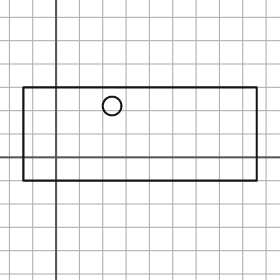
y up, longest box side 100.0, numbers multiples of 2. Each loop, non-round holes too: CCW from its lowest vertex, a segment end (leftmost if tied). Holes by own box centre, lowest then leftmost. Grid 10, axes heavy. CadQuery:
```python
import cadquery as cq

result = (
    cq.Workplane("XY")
    .moveTo(-14.0, -10.0)
    .lineTo(86.0, -10.0)
    .lineTo(86.0, 30.0)
    .lineTo(-14.0, 30.0)
    .close()
    .moveTo(24.0, 22.0)
    .circle(4.0)
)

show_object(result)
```